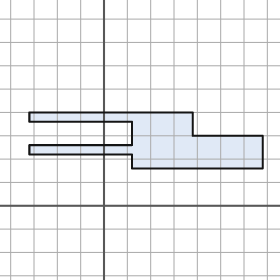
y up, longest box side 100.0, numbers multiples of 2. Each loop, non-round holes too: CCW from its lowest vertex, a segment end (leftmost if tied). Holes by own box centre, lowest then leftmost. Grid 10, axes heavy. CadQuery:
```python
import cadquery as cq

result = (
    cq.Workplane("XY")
    .moveTo(12.0, 16.0)
    .lineTo(68.0, 16.0)
    .lineTo(68.0, 30.0)
    .lineTo(38.0, 30.0)
    .lineTo(38.0, 40.0)
    .lineTo(-32.0, 40.0)
    .lineTo(-32.0, 36.0)
    .lineTo(12.0, 36.0)
    .lineTo(12.0, 26.0)
    .lineTo(-32.0, 26.0)
    .lineTo(-32.0, 22.0)
    .lineTo(12.0, 22.0)
    .close()
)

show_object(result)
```